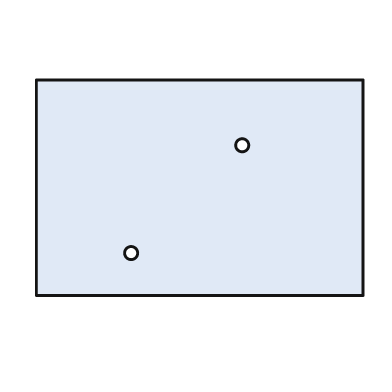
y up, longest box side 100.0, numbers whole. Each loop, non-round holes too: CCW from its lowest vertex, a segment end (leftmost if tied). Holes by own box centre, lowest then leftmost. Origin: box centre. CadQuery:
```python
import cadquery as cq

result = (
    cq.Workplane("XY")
    .moveTo(-50.0, -33.0)
    .lineTo(50.0, -33.0)
    .lineTo(50.0, 33.0)
    .lineTo(-50.0, 33.0)
    .close()
    .moveTo(-21.0, -20.0)
    .circle(2.0)
    .moveTo(13.0, 13.0)
    .circle(2.0)
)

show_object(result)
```